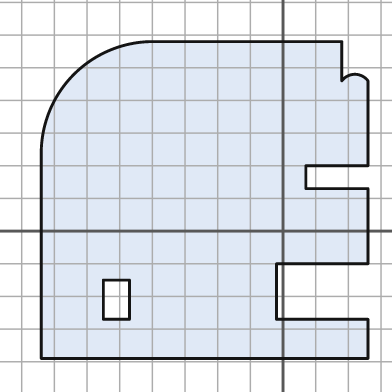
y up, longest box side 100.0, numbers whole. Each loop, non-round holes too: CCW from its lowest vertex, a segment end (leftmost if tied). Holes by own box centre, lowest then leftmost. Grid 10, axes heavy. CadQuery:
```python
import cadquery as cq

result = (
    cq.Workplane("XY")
    .moveTo(-74.0, -39.0)
    .lineTo(26.0, -39.0)
    .lineTo(26.0, -27.0)
    .lineTo(-2.0, -27.0)
    .lineTo(-2.0, -10.0)
    .lineTo(26.0, -10.0)
    .lineTo(26.0, 13.0)
    .lineTo(7.0, 13.0)
    .lineTo(7.0, 20.0)
    .lineTo(26.0, 20.0)
    .lineTo(26.0, 46.0)
    .threePointArc((22.0, 48.0), (18.0, 46.0))
    .lineTo(18.0, 58.0)
    .lineTo(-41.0, 58.0)
    .threePointArc((-64.0, 48.0), (-74.0, 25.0))
    .close()
    .moveTo(-55.0, -27.0)
    .lineTo(-47.0, -27.0)
    .lineTo(-47.0, -15.0)
    .lineTo(-55.0, -15.0)
    .close()
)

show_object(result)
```